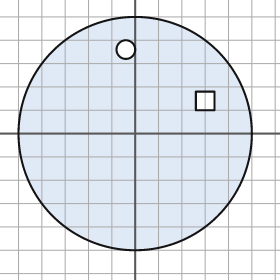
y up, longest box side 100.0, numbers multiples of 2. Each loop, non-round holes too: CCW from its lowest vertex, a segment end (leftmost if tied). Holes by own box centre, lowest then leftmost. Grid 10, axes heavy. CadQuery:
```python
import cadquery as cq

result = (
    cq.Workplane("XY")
    .moveTo(0.0, 0.0)
    .circle(50.0)
    .moveTo(26.0, 10.0)
    .lineTo(34.0, 10.0)
    .lineTo(34.0, 18.0)
    .lineTo(26.0, 18.0)
    .close()
    .moveTo(-4.0, 36.0)
    .circle(4.0)
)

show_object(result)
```